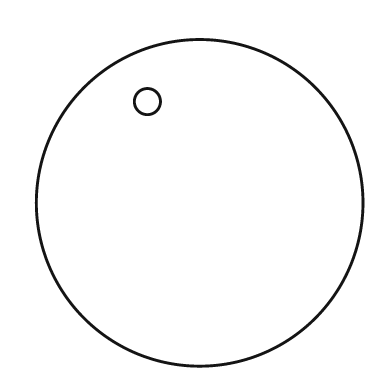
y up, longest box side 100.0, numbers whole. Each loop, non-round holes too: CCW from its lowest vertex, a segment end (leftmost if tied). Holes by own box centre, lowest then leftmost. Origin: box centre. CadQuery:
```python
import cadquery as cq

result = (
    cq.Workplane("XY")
    .moveTo(0.0, 0.0)
    .circle(50.0)
    .moveTo(-16.0, 31.0)
    .circle(4.0)
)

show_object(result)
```